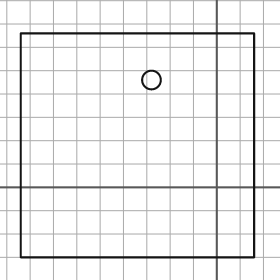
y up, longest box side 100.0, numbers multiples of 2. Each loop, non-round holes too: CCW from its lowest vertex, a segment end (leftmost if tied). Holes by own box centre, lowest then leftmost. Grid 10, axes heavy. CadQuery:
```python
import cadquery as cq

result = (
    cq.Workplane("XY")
    .moveTo(-84.0, -30.0)
    .lineTo(16.0, -30.0)
    .lineTo(16.0, 66.0)
    .lineTo(-84.0, 66.0)
    .close()
    .moveTo(-28.0, 46.0)
    .circle(4.0)
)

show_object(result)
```